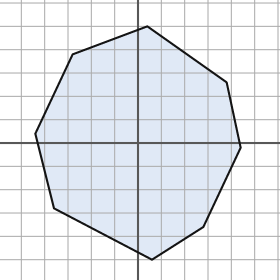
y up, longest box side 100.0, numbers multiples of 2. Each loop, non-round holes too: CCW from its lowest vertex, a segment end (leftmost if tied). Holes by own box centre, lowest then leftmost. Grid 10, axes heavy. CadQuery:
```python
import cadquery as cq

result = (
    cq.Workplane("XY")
    .moveTo(6.0, -50.0)
    .lineTo(28.0, -36.0)
    .lineTo(44.0, -2.0)
    .lineTo(38.0, 26.0)
    .lineTo(4.0, 50.0)
    .lineTo(-28.0, 38.0)
    .lineTo(-44.0, 4.0)
    .lineTo(-36.0, -28.0)
    .close()
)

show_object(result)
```